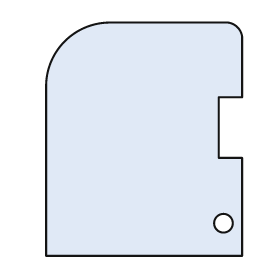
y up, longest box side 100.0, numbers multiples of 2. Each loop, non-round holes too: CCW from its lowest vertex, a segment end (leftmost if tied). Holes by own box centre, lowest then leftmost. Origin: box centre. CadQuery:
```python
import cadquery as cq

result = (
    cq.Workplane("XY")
    .moveTo(-42.0, -50.0)
    .lineTo(42.0, -50.0)
    .lineTo(42.0, -8.0)
    .lineTo(32.0, -8.0)
    .lineTo(32.0, 18.0)
    .lineTo(42.0, 18.0)
    .lineTo(42.0, 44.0)
    .threePointArc((40.0, 48.0), (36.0, 50.0))
    .lineTo(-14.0, 50.0)
    .threePointArc((-34.0, 42.0), (-42.0, 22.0))
    .close()
    .moveTo(34.0, -36.0)
    .circle(4.0)
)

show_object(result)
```